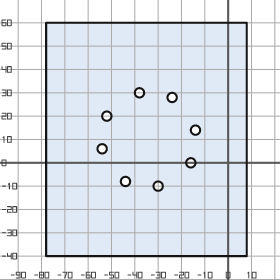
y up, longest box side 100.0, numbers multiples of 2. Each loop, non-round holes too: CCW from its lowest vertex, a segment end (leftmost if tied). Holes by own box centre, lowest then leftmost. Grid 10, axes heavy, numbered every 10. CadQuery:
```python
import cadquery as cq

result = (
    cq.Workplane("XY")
    .moveTo(-78.0, -40.0)
    .lineTo(8.0, -40.0)
    .lineTo(8.0, 60.0)
    .lineTo(-78.0, 60.0)
    .close()
    .moveTo(-30.0, -10.0)
    .circle(2.0)
    .moveTo(-44.0, -8.0)
    .circle(2.0)
    .moveTo(-16.0, 0.0)
    .circle(2.0)
    .moveTo(-54.0, 6.0)
    .circle(2.0)
    .moveTo(-14.0, 14.0)
    .circle(2.0)
    .moveTo(-52.0, 20.0)
    .circle(2.0)
    .moveTo(-24.0, 28.0)
    .circle(2.0)
    .moveTo(-38.0, 30.0)
    .circle(2.0)
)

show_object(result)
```